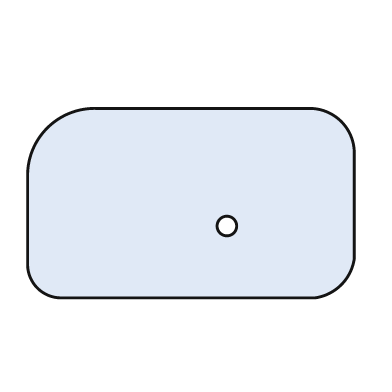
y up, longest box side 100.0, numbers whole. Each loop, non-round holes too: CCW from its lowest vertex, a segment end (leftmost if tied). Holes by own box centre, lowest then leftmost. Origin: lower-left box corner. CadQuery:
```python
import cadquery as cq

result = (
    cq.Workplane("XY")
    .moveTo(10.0, 0.0)
    .lineTo(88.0, 0.0)
    .threePointArc((96.0, 4.0), (100.0, 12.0))
    .lineTo(100.0, 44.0)
    .threePointArc((96.0, 54.0), (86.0, 58.0))
    .lineTo(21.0, 58.0)
    .threePointArc((6.0, 52.0), (0.0, 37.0))
    .lineTo(0.0, 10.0)
    .threePointArc((3.0, 3.0), (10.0, 0.0))
    .close()
    .moveTo(61.0, 22.0)
    .circle(3.0)
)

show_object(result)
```